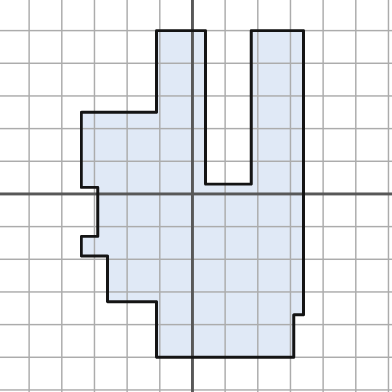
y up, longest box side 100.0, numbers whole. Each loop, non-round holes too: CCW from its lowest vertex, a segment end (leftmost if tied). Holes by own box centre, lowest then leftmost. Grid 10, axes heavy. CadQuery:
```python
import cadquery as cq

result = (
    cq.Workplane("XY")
    .moveTo(-11.0, -50.0)
    .lineTo(31.0, -50.0)
    .lineTo(31.0, -37.0)
    .lineTo(34.0, -37.0)
    .lineTo(34.0, 50.0)
    .lineTo(18.0, 50.0)
    .lineTo(18.0, 3.0)
    .lineTo(4.0, 3.0)
    .lineTo(4.0, 50.0)
    .lineTo(-11.0, 50.0)
    .lineTo(-11.0, 25.0)
    .lineTo(-34.0, 25.0)
    .lineTo(-34.0, 2.0)
    .lineTo(-29.0, 2.0)
    .lineTo(-29.0, -13.0)
    .lineTo(-34.0, -13.0)
    .lineTo(-34.0, -19.0)
    .lineTo(-26.0, -19.0)
    .lineTo(-26.0, -33.0)
    .lineTo(-11.0, -33.0)
    .close()
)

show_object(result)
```